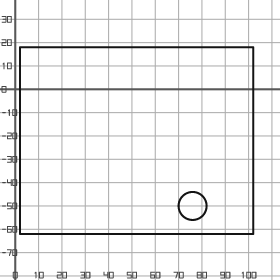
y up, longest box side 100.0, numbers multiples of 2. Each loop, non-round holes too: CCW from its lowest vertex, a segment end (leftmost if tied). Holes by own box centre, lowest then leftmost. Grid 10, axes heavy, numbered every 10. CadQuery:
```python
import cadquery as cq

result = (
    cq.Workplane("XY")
    .moveTo(2.0, -62.0)
    .lineTo(102.0, -62.0)
    .lineTo(102.0, 18.0)
    .lineTo(2.0, 18.0)
    .close()
    .moveTo(76.0, -50.0)
    .circle(6.0)
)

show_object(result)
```